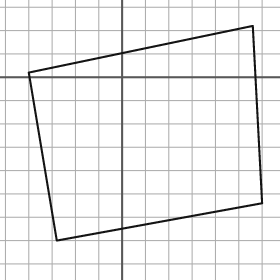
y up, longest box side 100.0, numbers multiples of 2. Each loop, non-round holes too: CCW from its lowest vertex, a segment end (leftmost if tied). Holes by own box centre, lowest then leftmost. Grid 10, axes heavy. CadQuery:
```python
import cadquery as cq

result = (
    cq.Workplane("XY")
    .moveTo(-28.0, -70.0)
    .lineTo(60.0, -54.0)
    .lineTo(56.0, 22.0)
    .lineTo(-40.0, 2.0)
    .close()
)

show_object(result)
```